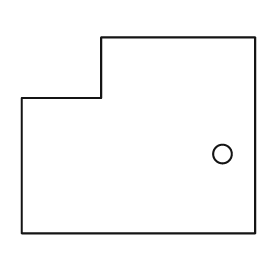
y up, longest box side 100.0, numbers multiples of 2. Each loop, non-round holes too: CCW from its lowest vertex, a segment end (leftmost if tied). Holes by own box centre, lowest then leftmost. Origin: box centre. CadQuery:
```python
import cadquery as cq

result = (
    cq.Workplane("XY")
    .moveTo(-50.0, -42.0)
    .lineTo(50.0, -42.0)
    .lineTo(50.0, 42.0)
    .lineTo(-16.0, 42.0)
    .lineTo(-16.0, 16.0)
    .lineTo(-50.0, 16.0)
    .close()
    .moveTo(36.0, -8.0)
    .circle(4.0)
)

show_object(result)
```